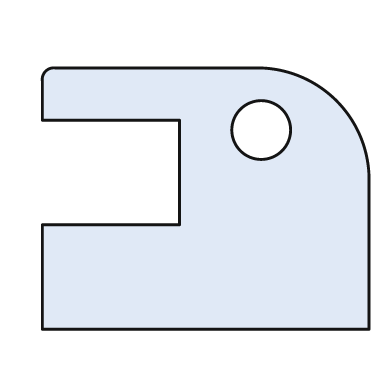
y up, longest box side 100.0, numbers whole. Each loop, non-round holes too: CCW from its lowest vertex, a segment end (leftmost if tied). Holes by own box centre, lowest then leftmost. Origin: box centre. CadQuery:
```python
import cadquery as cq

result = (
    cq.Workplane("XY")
    .moveTo(-50.0, -40.0)
    .lineTo(50.0, -40.0)
    .lineTo(50.0, 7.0)
    .threePointArc((40.0, 30.0), (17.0, 40.0))
    .lineTo(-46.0, 40.0)
    .threePointArc((-49.0, 39.0), (-50.0, 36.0))
    .lineTo(-50.0, 24.0)
    .lineTo(-8.0, 24.0)
    .lineTo(-8.0, -8.0)
    .lineTo(-50.0, -8.0)
    .close()
    .moveTo(17.0, 21.0)
    .circle(9.0)
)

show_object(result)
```